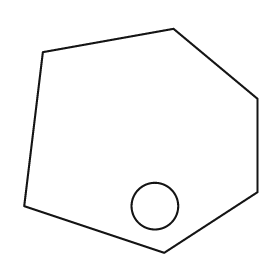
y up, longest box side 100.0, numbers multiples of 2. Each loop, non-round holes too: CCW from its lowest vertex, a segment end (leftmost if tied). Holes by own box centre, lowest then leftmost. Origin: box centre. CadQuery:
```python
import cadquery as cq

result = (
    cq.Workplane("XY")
    .moveTo(10.0, -48.0)
    .lineTo(50.0, -22.0)
    .lineTo(50.0, 18.0)
    .lineTo(14.0, 48.0)
    .lineTo(-42.0, 38.0)
    .lineTo(-50.0, -28.0)
    .close()
    .moveTo(6.0, -28.0)
    .circle(10.0)
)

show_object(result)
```